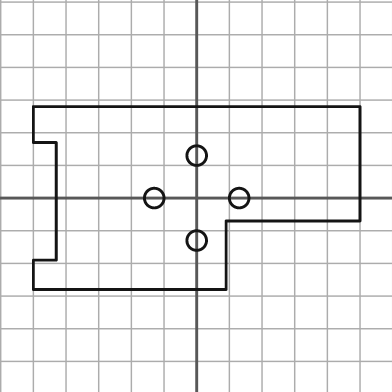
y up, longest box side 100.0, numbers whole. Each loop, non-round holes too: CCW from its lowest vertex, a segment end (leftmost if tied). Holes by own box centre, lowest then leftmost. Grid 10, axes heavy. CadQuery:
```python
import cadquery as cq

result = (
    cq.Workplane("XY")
    .moveTo(-50.0, -28.0)
    .lineTo(9.0, -28.0)
    .lineTo(9.0, -7.0)
    .lineTo(50.0, -7.0)
    .lineTo(50.0, 28.0)
    .lineTo(-50.0, 28.0)
    .lineTo(-50.0, 17.0)
    .lineTo(-43.0, 17.0)
    .lineTo(-43.0, -19.0)
    .lineTo(-50.0, -19.0)
    .close()
    .moveTo(0.0, -13.0)
    .circle(3.0)
    .moveTo(-13.0, 0.0)
    .circle(3.0)
    .moveTo(13.0, 0.0)
    .circle(3.0)
    .moveTo(0.0, 13.0)
    .circle(3.0)
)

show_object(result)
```